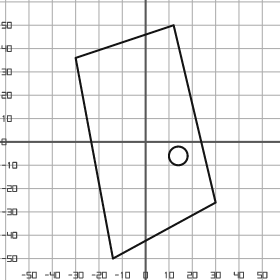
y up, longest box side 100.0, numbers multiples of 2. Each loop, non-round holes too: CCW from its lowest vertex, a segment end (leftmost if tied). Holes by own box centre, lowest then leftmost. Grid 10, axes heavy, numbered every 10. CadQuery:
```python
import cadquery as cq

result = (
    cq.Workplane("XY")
    .moveTo(-14.0, -50.0)
    .lineTo(30.0, -26.0)
    .lineTo(12.0, 50.0)
    .lineTo(-30.0, 36.0)
    .close()
    .moveTo(14.0, -6.0)
    .circle(4.0)
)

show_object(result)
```